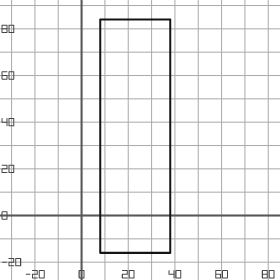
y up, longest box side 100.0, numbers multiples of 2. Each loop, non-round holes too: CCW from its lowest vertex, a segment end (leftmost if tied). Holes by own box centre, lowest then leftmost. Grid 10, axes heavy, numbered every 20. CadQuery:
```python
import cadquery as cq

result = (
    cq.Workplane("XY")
    .moveTo(8.0, -16.0)
    .lineTo(38.0, -16.0)
    .lineTo(38.0, 84.0)
    .lineTo(8.0, 84.0)
    .close()
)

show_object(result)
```